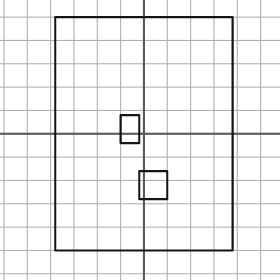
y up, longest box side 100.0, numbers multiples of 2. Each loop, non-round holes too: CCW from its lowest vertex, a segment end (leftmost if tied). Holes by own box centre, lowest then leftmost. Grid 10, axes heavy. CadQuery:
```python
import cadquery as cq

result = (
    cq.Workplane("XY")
    .moveTo(-38.0, -50.0)
    .lineTo(38.0, -50.0)
    .lineTo(38.0, 50.0)
    .lineTo(-38.0, 50.0)
    .close()
    .moveTo(-2.0, -28.0)
    .lineTo(10.0, -28.0)
    .lineTo(10.0, -16.0)
    .lineTo(-2.0, -16.0)
    .close()
    .moveTo(-10.0, -4.0)
    .lineTo(-2.0, -4.0)
    .lineTo(-2.0, 8.0)
    .lineTo(-10.0, 8.0)
    .close()
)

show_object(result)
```